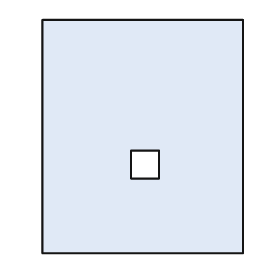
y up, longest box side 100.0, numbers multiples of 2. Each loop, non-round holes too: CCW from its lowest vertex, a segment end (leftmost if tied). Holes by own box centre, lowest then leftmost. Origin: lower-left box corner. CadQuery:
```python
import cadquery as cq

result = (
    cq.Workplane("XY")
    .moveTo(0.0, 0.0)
    .lineTo(86.0, 0.0)
    .lineTo(86.0, 100.0)
    .lineTo(0.0, 100.0)
    .close()
    .moveTo(38.0, 32.0)
    .lineTo(50.0, 32.0)
    .lineTo(50.0, 44.0)
    .lineTo(38.0, 44.0)
    .close()
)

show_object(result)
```